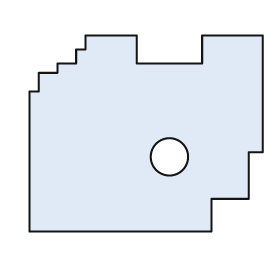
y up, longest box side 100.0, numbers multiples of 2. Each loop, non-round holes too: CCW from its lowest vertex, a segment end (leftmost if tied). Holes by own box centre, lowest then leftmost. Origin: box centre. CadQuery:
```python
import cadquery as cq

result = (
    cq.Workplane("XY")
    .moveTo(-50.0, -42.0)
    .lineTo(28.0, -42.0)
    .lineTo(28.0, -28.0)
    .lineTo(44.0, -28.0)
    .lineTo(44.0, -8.0)
    .lineTo(50.0, -8.0)
    .lineTo(50.0, 42.0)
    .lineTo(24.0, 42.0)
    .lineTo(24.0, 30.0)
    .lineTo(-4.0, 30.0)
    .lineTo(-4.0, 42.0)
    .lineTo(-26.0, 42.0)
    .lineTo(-26.0, 36.0)
    .lineTo(-30.0, 36.0)
    .lineTo(-30.0, 30.0)
    .lineTo(-38.0, 30.0)
    .lineTo(-38.0, 26.0)
    .lineTo(-46.0, 26.0)
    .lineTo(-46.0, 18.0)
    .lineTo(-50.0, 18.0)
    .close()
    .moveTo(10.0, -10.0)
    .circle(8.0)
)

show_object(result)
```